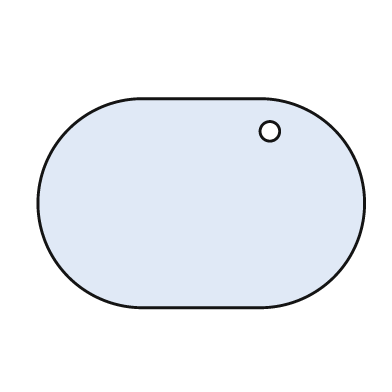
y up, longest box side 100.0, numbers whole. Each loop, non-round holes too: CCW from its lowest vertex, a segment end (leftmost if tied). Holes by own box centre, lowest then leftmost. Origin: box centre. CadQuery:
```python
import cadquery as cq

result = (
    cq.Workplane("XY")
    .moveTo(-18.0, -32.0)
    .lineTo(18.0, -32.0)
    .threePointArc((50.0, 0.0), (18.0, 32.0))
    .lineTo(-18.0, 32.0)
    .threePointArc((-50.0, 0.0), (-18.0, -32.0))
    .close()
    .moveTo(21.0, 22.0)
    .circle(3.0)
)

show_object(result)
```